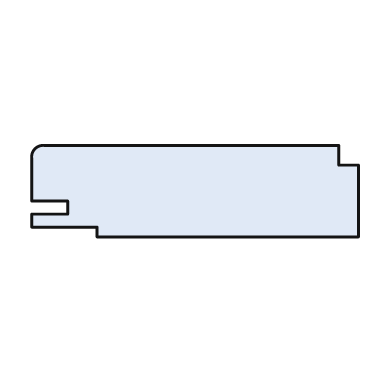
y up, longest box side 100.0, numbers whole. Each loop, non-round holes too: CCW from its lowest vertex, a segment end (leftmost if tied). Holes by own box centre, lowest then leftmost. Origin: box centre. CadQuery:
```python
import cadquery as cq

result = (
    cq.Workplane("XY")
    .moveTo(-30.0, -14.0)
    .lineTo(50.0, -14.0)
    .lineTo(50.0, 8.0)
    .lineTo(44.0, 8.0)
    .lineTo(44.0, 14.0)
    .lineTo(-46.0, 14.0)
    .threePointArc((-49.0, 13.0), (-50.0, 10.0))
    .lineTo(-50.0, -3.0)
    .lineTo(-39.0, -3.0)
    .lineTo(-39.0, -7.0)
    .lineTo(-50.0, -7.0)
    .lineTo(-50.0, -11.0)
    .lineTo(-30.0, -11.0)
    .close()
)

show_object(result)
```